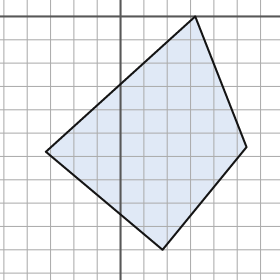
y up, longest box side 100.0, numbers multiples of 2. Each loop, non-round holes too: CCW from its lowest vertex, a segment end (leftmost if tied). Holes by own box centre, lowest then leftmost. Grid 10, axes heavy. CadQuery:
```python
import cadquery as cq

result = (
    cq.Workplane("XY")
    .moveTo(18.0, -100.0)
    .lineTo(54.0, -56.0)
    .lineTo(32.0, 0.0)
    .lineTo(-32.0, -58.0)
    .close()
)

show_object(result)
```